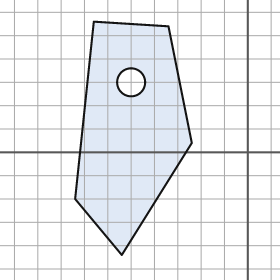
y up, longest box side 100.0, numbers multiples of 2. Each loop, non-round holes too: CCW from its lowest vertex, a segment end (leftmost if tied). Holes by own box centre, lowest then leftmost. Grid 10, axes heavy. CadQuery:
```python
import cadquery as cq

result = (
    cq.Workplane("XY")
    .moveTo(-54.0, -44.0)
    .lineTo(-24.0, 4.0)
    .lineTo(-34.0, 54.0)
    .lineTo(-66.0, 56.0)
    .lineTo(-74.0, -20.0)
    .close()
    .moveTo(-50.0, 30.0)
    .circle(6.0)
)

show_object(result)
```